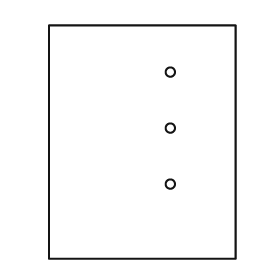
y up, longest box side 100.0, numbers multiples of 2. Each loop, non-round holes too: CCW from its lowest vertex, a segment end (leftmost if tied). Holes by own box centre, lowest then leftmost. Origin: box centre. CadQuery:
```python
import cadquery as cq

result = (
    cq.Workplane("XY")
    .moveTo(-40.0, -50.0)
    .lineTo(40.0, -50.0)
    .lineTo(40.0, 50.0)
    .lineTo(-40.0, 50.0)
    .close()
    .moveTo(12.0, -18.0)
    .circle(2.0)
    .moveTo(12.0, 6.0)
    .circle(2.0)
    .moveTo(12.0, 30.0)
    .circle(2.0)
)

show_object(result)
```